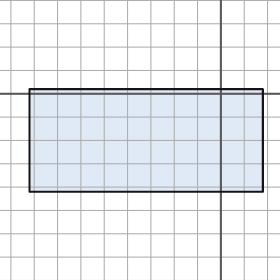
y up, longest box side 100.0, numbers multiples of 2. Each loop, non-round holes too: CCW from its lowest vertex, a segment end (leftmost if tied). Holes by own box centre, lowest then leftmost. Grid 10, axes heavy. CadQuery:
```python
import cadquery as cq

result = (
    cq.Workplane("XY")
    .moveTo(-82.0, -42.0)
    .lineTo(18.0, -42.0)
    .lineTo(18.0, 2.0)
    .lineTo(-82.0, 2.0)
    .close()
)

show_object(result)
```